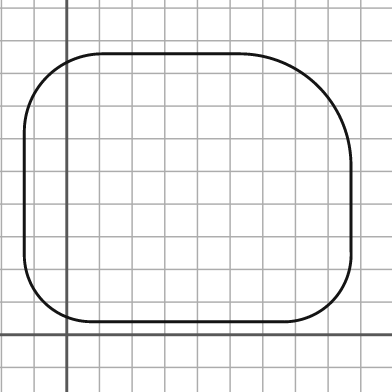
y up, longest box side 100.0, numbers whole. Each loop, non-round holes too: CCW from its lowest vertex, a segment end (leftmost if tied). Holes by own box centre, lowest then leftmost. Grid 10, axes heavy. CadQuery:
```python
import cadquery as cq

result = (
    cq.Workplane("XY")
    .moveTo(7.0, 4.0)
    .lineTo(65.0, 4.0)
    .threePointArc((81.0, 10.0), (87.0, 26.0))
    .lineTo(87.0, 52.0)
    .threePointArc((77.0, 76.0), (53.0, 86.0))
    .lineTo(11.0, 86.0)
    .threePointArc((-6.0, 79.0), (-13.0, 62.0))
    .lineTo(-13.0, 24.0)
    .threePointArc((-7.0, 10.0), (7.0, 4.0))
    .close()
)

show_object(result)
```